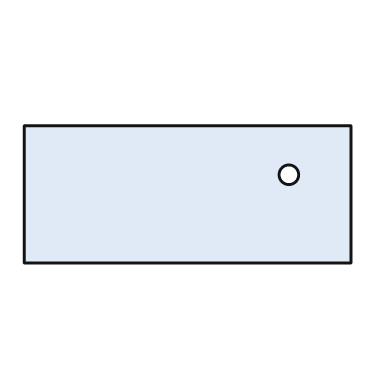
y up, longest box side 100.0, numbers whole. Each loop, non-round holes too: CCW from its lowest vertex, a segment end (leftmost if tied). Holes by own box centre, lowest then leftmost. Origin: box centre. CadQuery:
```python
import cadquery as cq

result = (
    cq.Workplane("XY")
    .moveTo(-50.0, -21.0)
    .lineTo(50.0, -21.0)
    .lineTo(50.0, 21.0)
    .lineTo(-50.0, 21.0)
    .close()
    .moveTo(31.0, 6.0)
    .circle(3.0)
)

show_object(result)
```